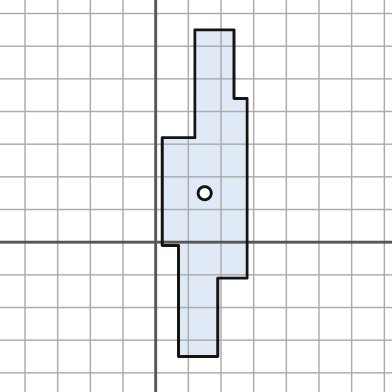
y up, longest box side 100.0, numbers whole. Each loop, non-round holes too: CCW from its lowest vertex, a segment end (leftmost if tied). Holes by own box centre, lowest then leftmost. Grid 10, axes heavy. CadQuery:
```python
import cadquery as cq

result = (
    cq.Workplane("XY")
    .moveTo(7.0, -35.0)
    .lineTo(19.0, -35.0)
    .lineTo(19.0, -11.0)
    .lineTo(28.0, -11.0)
    .lineTo(28.0, 44.0)
    .lineTo(24.0, 44.0)
    .lineTo(24.0, 65.0)
    .lineTo(12.0, 65.0)
    .lineTo(12.0, 32.0)
    .lineTo(2.0, 32.0)
    .lineTo(2.0, -1.0)
    .lineTo(7.0, -1.0)
    .close()
    .moveTo(15.0, 15.0)
    .circle(2.0)
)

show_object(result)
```